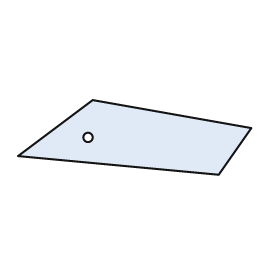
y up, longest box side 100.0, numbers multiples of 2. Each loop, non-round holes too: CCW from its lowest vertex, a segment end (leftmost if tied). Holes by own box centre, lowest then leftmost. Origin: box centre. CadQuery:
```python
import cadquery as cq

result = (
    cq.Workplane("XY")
    .moveTo(36.0, -16.0)
    .lineTo(50.0, 4.0)
    .lineTo(-18.0, 16.0)
    .lineTo(-50.0, -8.0)
    .close()
    .moveTo(-20.0, 0.0)
    .circle(2.0)
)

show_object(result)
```